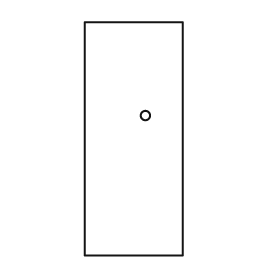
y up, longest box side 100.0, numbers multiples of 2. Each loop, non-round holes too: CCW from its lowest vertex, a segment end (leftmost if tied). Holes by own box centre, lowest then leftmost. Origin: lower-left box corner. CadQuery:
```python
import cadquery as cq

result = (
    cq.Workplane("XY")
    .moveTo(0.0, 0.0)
    .lineTo(42.0, 0.0)
    .lineTo(42.0, 100.0)
    .lineTo(0.0, 100.0)
    .close()
    .moveTo(26.0, 60.0)
    .circle(2.0)
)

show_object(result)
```